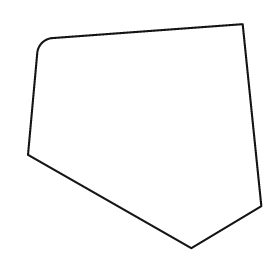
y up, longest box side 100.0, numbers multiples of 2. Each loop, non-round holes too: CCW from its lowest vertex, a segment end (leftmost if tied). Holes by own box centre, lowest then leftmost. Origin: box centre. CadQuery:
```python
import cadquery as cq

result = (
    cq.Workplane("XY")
    .moveTo(20.0, -48.0)
    .lineTo(50.0, -30.0)
    .lineTo(42.0, 48.0)
    .lineTo(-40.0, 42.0)
    .threePointArc((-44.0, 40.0), (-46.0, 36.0))
    .lineTo(-50.0, -8.0)
    .close()
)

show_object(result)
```